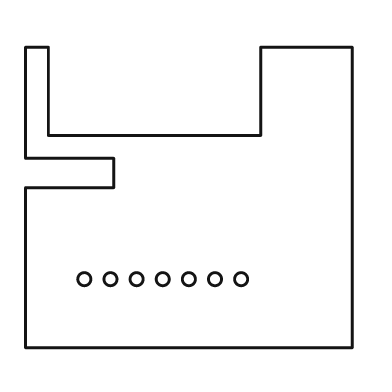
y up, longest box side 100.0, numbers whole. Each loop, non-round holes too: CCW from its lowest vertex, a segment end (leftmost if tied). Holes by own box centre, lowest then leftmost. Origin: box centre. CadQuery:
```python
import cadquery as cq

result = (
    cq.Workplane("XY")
    .moveTo(-50.0, -46.0)
    .lineTo(50.0, -46.0)
    .lineTo(50.0, 46.0)
    .lineTo(22.0, 46.0)
    .lineTo(22.0, 19.0)
    .lineTo(-43.0, 19.0)
    .lineTo(-43.0, 46.0)
    .lineTo(-50.0, 46.0)
    .lineTo(-50.0, 12.0)
    .lineTo(-23.0, 12.0)
    .lineTo(-23.0, 3.0)
    .lineTo(-50.0, 3.0)
    .close()
    .moveTo(-32.0, -25.0)
    .circle(2.0)
    .moveTo(-24.0, -25.0)
    .circle(2.0)
    .moveTo(-16.0, -25.0)
    .circle(2.0)
    .moveTo(-8.0, -25.0)
    .circle(2.0)
    .moveTo(0.0, -25.0)
    .circle(2.0)
    .moveTo(8.0, -25.0)
    .circle(2.0)
    .moveTo(16.0, -25.0)
    .circle(2.0)
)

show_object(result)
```